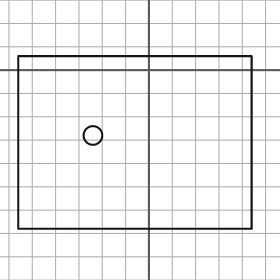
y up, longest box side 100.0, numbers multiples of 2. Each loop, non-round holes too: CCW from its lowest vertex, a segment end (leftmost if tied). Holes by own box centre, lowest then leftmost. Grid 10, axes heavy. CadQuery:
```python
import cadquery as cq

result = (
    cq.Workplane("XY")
    .moveTo(-56.0, -68.0)
    .lineTo(44.0, -68.0)
    .lineTo(44.0, 6.0)
    .lineTo(-56.0, 6.0)
    .close()
    .moveTo(-24.0, -28.0)
    .circle(4.0)
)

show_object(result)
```